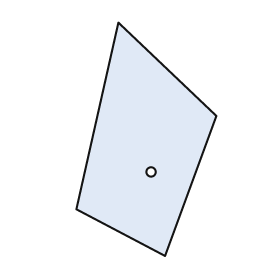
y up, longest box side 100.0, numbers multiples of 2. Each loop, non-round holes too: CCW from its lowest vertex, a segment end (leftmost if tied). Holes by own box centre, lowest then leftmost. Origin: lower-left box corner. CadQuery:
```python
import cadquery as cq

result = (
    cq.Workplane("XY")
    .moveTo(38.0, 0.0)
    .lineTo(60.0, 60.0)
    .lineTo(18.0, 100.0)
    .lineTo(0.0, 20.0)
    .close()
    .moveTo(32.0, 36.0)
    .circle(2.0)
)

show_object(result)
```